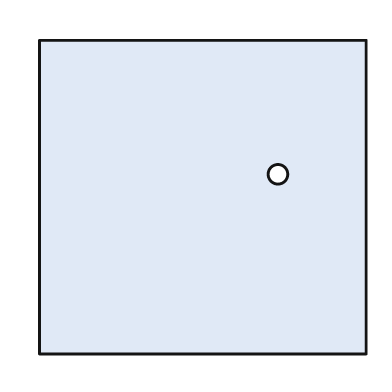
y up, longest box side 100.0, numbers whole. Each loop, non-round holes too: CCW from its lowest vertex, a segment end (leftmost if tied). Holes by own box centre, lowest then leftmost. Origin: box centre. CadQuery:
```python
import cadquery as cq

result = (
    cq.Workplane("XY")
    .moveTo(-50.0, -48.0)
    .lineTo(50.0, -48.0)
    .lineTo(50.0, 48.0)
    .lineTo(-50.0, 48.0)
    .close()
    .moveTo(23.0, 7.0)
    .circle(3.0)
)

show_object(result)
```